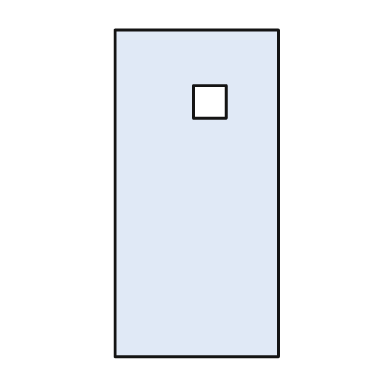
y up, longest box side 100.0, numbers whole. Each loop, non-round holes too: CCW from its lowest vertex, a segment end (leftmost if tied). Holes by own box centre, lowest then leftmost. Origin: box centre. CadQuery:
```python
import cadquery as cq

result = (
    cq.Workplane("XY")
    .moveTo(-25.0, -50.0)
    .lineTo(25.0, -50.0)
    .lineTo(25.0, 50.0)
    .lineTo(-25.0, 50.0)
    .close()
    .moveTo(-1.0, 23.0)
    .lineTo(9.0, 23.0)
    .lineTo(9.0, 33.0)
    .lineTo(-1.0, 33.0)
    .close()
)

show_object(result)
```